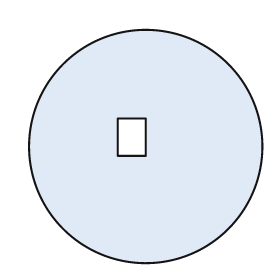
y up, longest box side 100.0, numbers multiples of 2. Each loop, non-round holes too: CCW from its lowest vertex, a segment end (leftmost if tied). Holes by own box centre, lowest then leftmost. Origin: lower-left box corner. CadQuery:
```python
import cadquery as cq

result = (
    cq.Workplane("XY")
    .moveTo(50.0, 50.0)
    .circle(50.0)
    .moveTo(38.0, 46.0)
    .lineTo(50.0, 46.0)
    .lineTo(50.0, 62.0)
    .lineTo(38.0, 62.0)
    .close()
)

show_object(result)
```